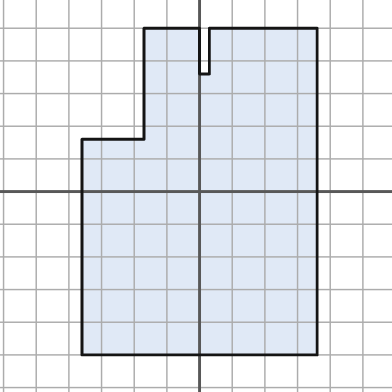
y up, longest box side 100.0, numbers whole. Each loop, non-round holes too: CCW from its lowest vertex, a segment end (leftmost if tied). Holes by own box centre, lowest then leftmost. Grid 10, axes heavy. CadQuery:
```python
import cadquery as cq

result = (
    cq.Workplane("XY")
    .moveTo(-36.0, -50.0)
    .lineTo(36.0, -50.0)
    .lineTo(36.0, 50.0)
    .lineTo(3.0, 50.0)
    .lineTo(3.0, 36.0)
    .lineTo(0.0, 36.0)
    .lineTo(0.0, 50.0)
    .lineTo(-17.0, 50.0)
    .lineTo(-17.0, 16.0)
    .lineTo(-36.0, 16.0)
    .close()
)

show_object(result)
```